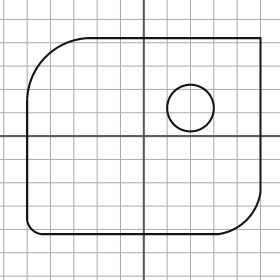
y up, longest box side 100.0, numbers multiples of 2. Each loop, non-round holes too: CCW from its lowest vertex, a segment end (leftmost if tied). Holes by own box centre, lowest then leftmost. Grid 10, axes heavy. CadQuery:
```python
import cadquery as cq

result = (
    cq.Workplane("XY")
    .moveTo(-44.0, -42.0)
    .lineTo(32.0, -42.0)
    .threePointArc((44.0, -36.0), (50.0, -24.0))
    .lineTo(50.0, 42.0)
    .lineTo(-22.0, 42.0)
    .threePointArc((-42.0, 34.0), (-50.0, 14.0))
    .lineTo(-50.0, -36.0)
    .threePointArc((-48.0, -40.0), (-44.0, -42.0))
    .close()
    .moveTo(20.0, 12.0)
    .circle(10.0)
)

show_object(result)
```